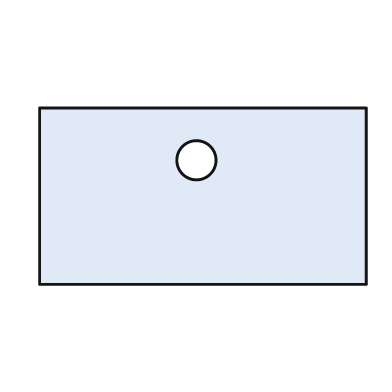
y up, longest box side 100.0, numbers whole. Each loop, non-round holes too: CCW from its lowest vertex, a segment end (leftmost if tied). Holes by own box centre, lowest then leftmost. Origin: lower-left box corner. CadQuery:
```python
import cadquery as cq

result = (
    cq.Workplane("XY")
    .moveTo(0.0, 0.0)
    .lineTo(100.0, 0.0)
    .lineTo(100.0, 54.0)
    .lineTo(0.0, 54.0)
    .close()
    .moveTo(48.0, 38.0)
    .circle(6.0)
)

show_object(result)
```